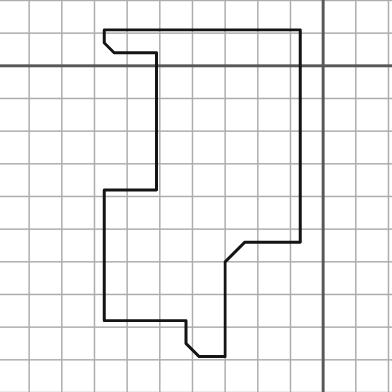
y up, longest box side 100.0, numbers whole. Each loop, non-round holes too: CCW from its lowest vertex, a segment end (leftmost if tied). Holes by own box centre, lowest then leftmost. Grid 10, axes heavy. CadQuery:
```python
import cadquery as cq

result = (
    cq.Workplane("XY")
    .moveTo(-38.0, -89.0)
    .lineTo(-30.0, -89.0)
    .lineTo(-30.0, -60.0)
    .lineTo(-24.0, -54.0)
    .lineTo(-7.0, -54.0)
    .lineTo(-7.0, 11.0)
    .lineTo(-67.0, 11.0)
    .lineTo(-67.0, 7.0)
    .lineTo(-64.0, 4.0)
    .lineTo(-51.0, 4.0)
    .lineTo(-51.0, -38.0)
    .lineTo(-67.0, -38.0)
    .lineTo(-67.0, -78.0)
    .lineTo(-42.0, -78.0)
    .lineTo(-42.0, -85.0)
    .close()
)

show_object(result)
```